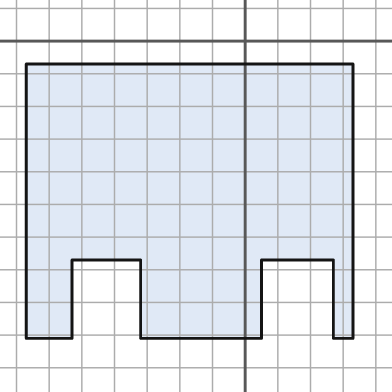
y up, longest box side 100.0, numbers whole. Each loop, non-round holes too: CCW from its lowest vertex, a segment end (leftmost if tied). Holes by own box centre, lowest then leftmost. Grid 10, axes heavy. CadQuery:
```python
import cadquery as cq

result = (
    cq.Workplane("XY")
    .moveTo(-67.0, -91.0)
    .lineTo(-53.0, -91.0)
    .lineTo(-53.0, -67.0)
    .lineTo(-32.0, -67.0)
    .lineTo(-32.0, -91.0)
    .lineTo(5.0, -91.0)
    .lineTo(5.0, -67.0)
    .lineTo(27.0, -67.0)
    .lineTo(27.0, -91.0)
    .lineTo(33.0, -91.0)
    .lineTo(33.0, -7.0)
    .lineTo(-67.0, -7.0)
    .close()
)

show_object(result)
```